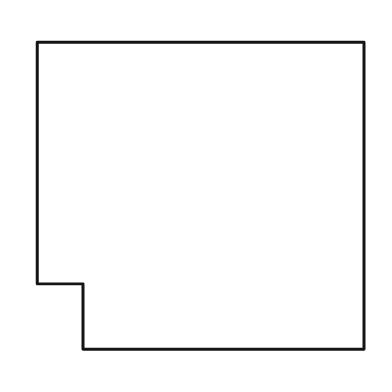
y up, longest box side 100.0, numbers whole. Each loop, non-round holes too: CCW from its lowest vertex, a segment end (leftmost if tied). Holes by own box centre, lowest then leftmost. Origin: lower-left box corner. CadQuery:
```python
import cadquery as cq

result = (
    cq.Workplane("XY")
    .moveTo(14.0, 0.0)
    .lineTo(100.0, 0.0)
    .lineTo(100.0, 94.0)
    .lineTo(0.0, 94.0)
    .lineTo(0.0, 20.0)
    .lineTo(14.0, 20.0)
    .close()
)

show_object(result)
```